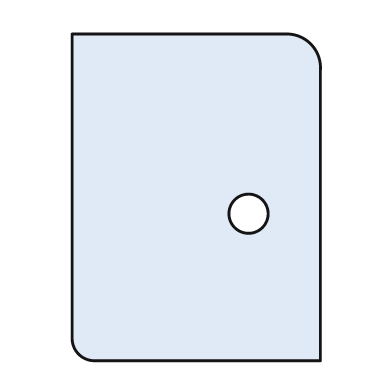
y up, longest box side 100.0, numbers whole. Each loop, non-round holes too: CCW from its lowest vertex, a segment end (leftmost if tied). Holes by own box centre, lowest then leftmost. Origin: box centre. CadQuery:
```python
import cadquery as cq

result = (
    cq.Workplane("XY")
    .moveTo(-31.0, -50.0)
    .lineTo(38.0, -50.0)
    .lineTo(38.0, 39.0)
    .threePointArc((35.0, 47.0), (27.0, 50.0))
    .lineTo(-38.0, 50.0)
    .lineTo(-38.0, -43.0)
    .threePointArc((-36.0, -48.0), (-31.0, -50.0))
    .close()
    .moveTo(16.0, -5.0)
    .circle(6.0)
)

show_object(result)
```